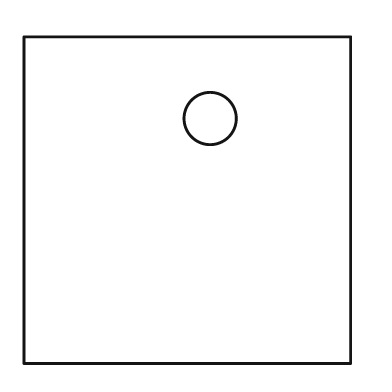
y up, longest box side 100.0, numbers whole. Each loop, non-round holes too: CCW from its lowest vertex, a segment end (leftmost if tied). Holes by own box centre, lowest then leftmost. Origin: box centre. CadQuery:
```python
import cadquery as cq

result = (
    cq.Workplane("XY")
    .moveTo(-50.0, -50.0)
    .lineTo(50.0, -50.0)
    .lineTo(50.0, 50.0)
    .lineTo(-50.0, 50.0)
    .close()
    .moveTo(7.0, 25.0)
    .circle(8.0)
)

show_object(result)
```